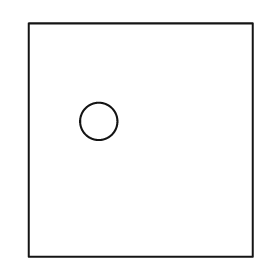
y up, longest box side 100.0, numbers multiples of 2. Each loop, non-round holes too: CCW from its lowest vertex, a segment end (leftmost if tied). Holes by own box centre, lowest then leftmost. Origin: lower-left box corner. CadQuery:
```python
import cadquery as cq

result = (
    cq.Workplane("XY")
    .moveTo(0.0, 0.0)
    .lineTo(96.0, 0.0)
    .lineTo(96.0, 100.0)
    .lineTo(0.0, 100.0)
    .close()
    .moveTo(30.0, 58.0)
    .circle(8.0)
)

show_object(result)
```